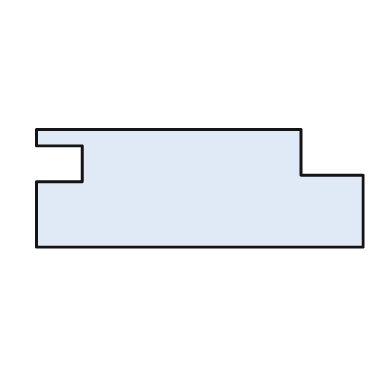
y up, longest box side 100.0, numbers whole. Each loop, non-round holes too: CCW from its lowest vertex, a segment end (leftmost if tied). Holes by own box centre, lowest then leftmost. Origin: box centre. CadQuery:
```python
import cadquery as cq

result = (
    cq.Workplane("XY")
    .moveTo(-50.0, -18.0)
    .lineTo(50.0, -18.0)
    .lineTo(50.0, 4.0)
    .lineTo(31.0, 4.0)
    .lineTo(31.0, 18.0)
    .lineTo(-50.0, 18.0)
    .lineTo(-50.0, 13.0)
    .lineTo(-36.0, 13.0)
    .lineTo(-36.0, 2.0)
    .lineTo(-50.0, 2.0)
    .close()
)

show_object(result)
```